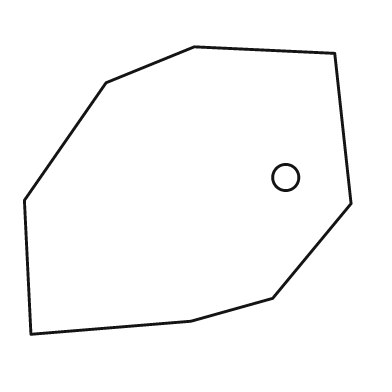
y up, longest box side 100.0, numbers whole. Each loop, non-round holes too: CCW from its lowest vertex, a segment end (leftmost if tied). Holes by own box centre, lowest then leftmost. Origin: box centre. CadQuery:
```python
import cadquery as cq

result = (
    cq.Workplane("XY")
    .moveTo(-48.0, -44.0)
    .lineTo(1.0, -40.0)
    .lineTo(26.0, -33.0)
    .lineTo(50.0, -4.0)
    .lineTo(45.0, 42.0)
    .lineTo(2.0, 44.0)
    .lineTo(-25.0, 33.0)
    .lineTo(-50.0, -3.0)
    .close()
    .moveTo(30.0, 4.0)
    .circle(4.0)
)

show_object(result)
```